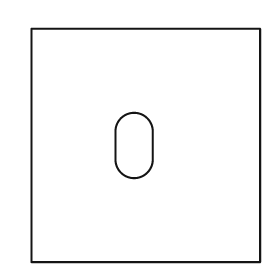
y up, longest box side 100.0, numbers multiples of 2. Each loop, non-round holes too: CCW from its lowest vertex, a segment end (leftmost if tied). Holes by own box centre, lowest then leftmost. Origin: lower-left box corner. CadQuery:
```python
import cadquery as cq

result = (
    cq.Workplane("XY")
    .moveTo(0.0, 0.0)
    .lineTo(98.0, 0.0)
    .lineTo(98.0, 100.0)
    .lineTo(0.0, 100.0)
    .close()
    .moveTo(36.0, 44.0)
    .threePointArc((44.0, 36.0), (52.0, 44.0))
    .lineTo(52.0, 56.0)
    .threePointArc((44.0, 64.0), (36.0, 56.0))
    .close()
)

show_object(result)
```